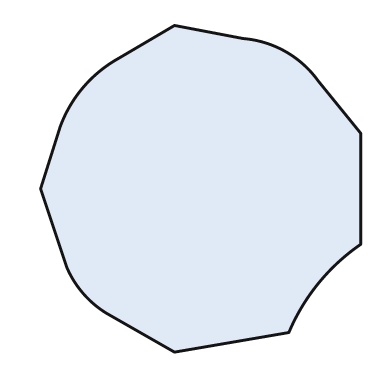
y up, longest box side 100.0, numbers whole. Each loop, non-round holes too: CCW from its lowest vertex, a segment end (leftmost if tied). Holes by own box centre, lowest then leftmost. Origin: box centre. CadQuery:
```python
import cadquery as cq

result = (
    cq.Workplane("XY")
    .moveTo(-8.0, -50.0)
    .lineTo(27.0, -44.0)
    .threePointArc((36.0, -29.0), (49.0, -17.0))
    .lineTo(49.0, 17.0)
    .lineTo(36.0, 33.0)
    .threePointArc((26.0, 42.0), (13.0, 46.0))
    .lineTo(-8.0, 50.0)
    .lineTo(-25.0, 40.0)
    .threePointArc((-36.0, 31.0), (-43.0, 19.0))
    .lineTo(-49.0, 0.0)
    .lineTo(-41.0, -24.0)
    .threePointArc((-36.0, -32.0), (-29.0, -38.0))
    .close()
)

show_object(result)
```